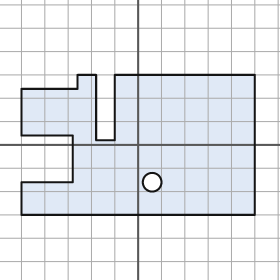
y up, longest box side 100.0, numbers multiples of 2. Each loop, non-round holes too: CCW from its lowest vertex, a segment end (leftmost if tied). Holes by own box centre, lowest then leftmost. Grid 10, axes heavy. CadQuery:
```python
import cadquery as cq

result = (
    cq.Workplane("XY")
    .moveTo(-50.0, -30.0)
    .lineTo(50.0, -30.0)
    .lineTo(50.0, 30.0)
    .lineTo(-10.0, 30.0)
    .lineTo(-10.0, 2.0)
    .lineTo(-18.0, 2.0)
    .lineTo(-18.0, 30.0)
    .lineTo(-26.0, 30.0)
    .lineTo(-26.0, 24.0)
    .lineTo(-50.0, 24.0)
    .lineTo(-50.0, 4.0)
    .lineTo(-28.0, 4.0)
    .lineTo(-28.0, -16.0)
    .lineTo(-50.0, -16.0)
    .close()
    .moveTo(6.0, -16.0)
    .circle(4.0)
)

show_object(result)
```